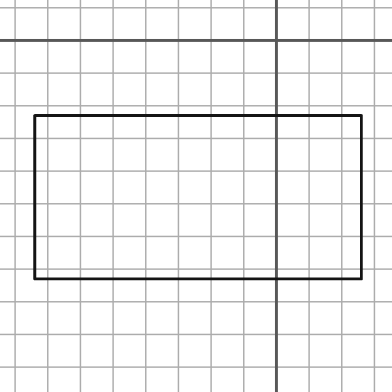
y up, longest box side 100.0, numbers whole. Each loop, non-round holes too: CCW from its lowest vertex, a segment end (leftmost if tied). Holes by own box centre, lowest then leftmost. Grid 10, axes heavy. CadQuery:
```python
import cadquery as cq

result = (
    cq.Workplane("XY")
    .moveTo(-74.0, -73.0)
    .lineTo(26.0, -73.0)
    .lineTo(26.0, -23.0)
    .lineTo(-74.0, -23.0)
    .close()
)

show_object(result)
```